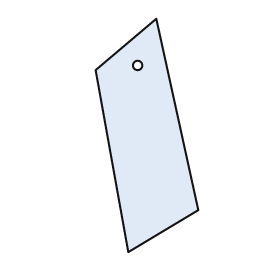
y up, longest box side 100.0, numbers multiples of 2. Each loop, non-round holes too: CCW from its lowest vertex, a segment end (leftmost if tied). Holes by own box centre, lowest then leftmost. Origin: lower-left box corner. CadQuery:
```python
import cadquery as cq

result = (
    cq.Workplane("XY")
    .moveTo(14.0, 0.0)
    .lineTo(44.0, 18.0)
    .lineTo(26.0, 100.0)
    .lineTo(0.0, 78.0)
    .close()
    .moveTo(18.0, 80.0)
    .circle(2.0)
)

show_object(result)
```